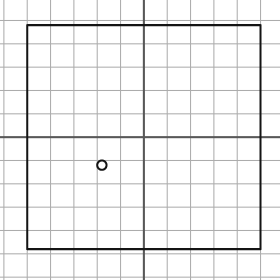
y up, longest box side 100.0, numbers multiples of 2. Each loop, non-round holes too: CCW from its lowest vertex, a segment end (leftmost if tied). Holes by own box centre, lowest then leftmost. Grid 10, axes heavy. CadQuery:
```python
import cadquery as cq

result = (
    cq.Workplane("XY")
    .moveTo(-50.0, -48.0)
    .lineTo(50.0, -48.0)
    .lineTo(50.0, 48.0)
    .lineTo(-50.0, 48.0)
    .close()
    .moveTo(-18.0, -12.0)
    .circle(2.0)
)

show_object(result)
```